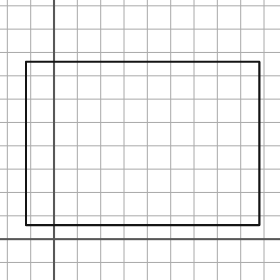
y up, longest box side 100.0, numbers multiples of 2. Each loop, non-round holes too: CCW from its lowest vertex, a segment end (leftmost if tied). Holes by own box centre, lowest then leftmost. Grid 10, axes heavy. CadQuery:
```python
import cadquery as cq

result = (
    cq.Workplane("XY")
    .moveTo(-12.0, 6.0)
    .lineTo(88.0, 6.0)
    .lineTo(88.0, 76.0)
    .lineTo(-12.0, 76.0)
    .close()
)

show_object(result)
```